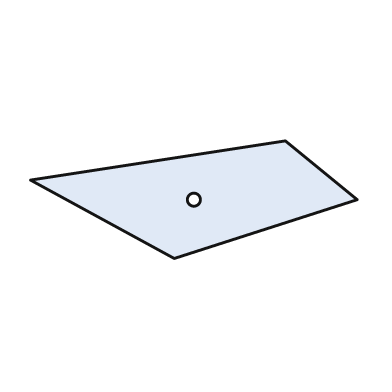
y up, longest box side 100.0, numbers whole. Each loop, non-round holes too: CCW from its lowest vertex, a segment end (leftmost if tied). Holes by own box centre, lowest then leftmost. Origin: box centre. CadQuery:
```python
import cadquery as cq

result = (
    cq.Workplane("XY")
    .moveTo(-6.0, -18.0)
    .lineTo(50.0, 0.0)
    .lineTo(28.0, 18.0)
    .lineTo(-50.0, 6.0)
    .close()
    .moveTo(0.0, 0.0)
    .circle(2.0)
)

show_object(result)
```